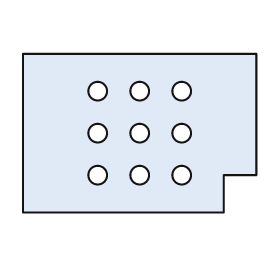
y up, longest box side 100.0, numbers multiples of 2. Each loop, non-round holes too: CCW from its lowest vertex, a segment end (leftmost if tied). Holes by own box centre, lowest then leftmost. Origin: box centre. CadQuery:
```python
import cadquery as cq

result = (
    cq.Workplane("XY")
    .moveTo(-50.0, -34.0)
    .lineTo(36.0, -34.0)
    .lineTo(36.0, -18.0)
    .lineTo(50.0, -18.0)
    .lineTo(50.0, 34.0)
    .lineTo(-50.0, 34.0)
    .close()
    .moveTo(-18.0, -18.0)
    .circle(4.0)
    .moveTo(0.0, -18.0)
    .circle(4.0)
    .moveTo(18.0, -18.0)
    .circle(4.0)
    .moveTo(-18.0, 0.0)
    .circle(4.0)
    .moveTo(0.0, 0.0)
    .circle(4.0)
    .moveTo(18.0, 0.0)
    .circle(4.0)
    .moveTo(-18.0, 18.0)
    .circle(4.0)
    .moveTo(0.0, 18.0)
    .circle(4.0)
    .moveTo(18.0, 18.0)
    .circle(4.0)
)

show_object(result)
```